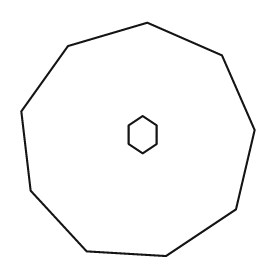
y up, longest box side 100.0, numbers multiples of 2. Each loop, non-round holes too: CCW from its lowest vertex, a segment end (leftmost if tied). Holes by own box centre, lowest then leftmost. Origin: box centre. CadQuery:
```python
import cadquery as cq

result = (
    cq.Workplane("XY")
    .moveTo(12.0, -50.0)
    .lineTo(42.0, -30.0)
    .lineTo(50.0, 4.0)
    .lineTo(36.0, 36.0)
    .lineTo(4.0, 50.0)
    .lineTo(-30.0, 40.0)
    .lineTo(-50.0, 12.0)
    .lineTo(-46.0, -22.0)
    .lineTo(-22.0, -48.0)
    .close()
    .moveTo(2.0, -6.0)
    .lineTo(8.0, -2.0)
    .lineTo(8.0, 6.0)
    .lineTo(2.0, 10.0)
    .lineTo(-4.0, 6.0)
    .lineTo(-4.0, -2.0)
    .close()
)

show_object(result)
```